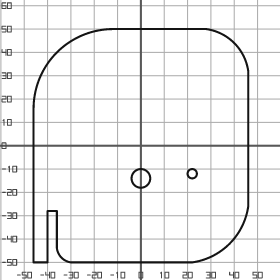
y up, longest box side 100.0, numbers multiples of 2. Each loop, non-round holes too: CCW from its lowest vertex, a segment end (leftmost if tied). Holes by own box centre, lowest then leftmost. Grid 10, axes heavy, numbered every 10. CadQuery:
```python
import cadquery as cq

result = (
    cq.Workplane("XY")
    .moveTo(-46.0, -50.0)
    .lineTo(-40.0, -50.0)
    .lineTo(-40.0, -28.0)
    .lineTo(-36.0, -28.0)
    .lineTo(-36.0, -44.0)
    .threePointArc((-34.0, -48.0), (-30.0, -50.0))
    .lineTo(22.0, -50.0)
    .threePointArc((38.0, -42.0), (46.0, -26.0))
    .lineTo(46.0, 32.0)
    .threePointArc((40.0, 44.0), (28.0, 50.0))
    .lineTo(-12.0, 50.0)
    .threePointArc((-36.0, 40.0), (-46.0, 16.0))
    .close()
    .moveTo(0.0, -14.0)
    .circle(4.0)
    .moveTo(22.0, -12.0)
    .circle(2.0)
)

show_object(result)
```